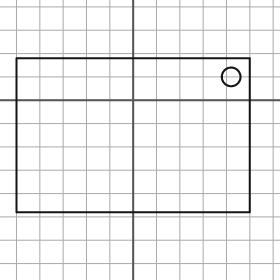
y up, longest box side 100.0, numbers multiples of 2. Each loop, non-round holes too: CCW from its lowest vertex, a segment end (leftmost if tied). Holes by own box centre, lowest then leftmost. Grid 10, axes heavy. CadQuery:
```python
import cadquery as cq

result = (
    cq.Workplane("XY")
    .moveTo(-50.0, -48.0)
    .lineTo(50.0, -48.0)
    .lineTo(50.0, 18.0)
    .lineTo(-50.0, 18.0)
    .close()
    .moveTo(42.0, 10.0)
    .circle(4.0)
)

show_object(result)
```